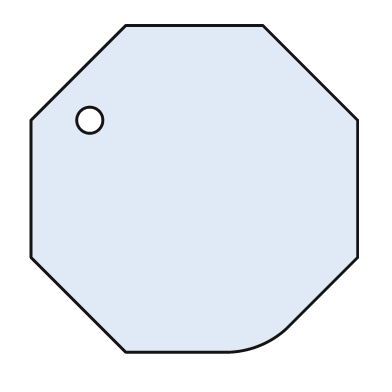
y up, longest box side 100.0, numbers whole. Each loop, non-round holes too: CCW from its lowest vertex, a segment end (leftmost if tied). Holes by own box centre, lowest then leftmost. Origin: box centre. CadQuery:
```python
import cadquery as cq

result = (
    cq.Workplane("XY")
    .moveTo(-21.0, -50.0)
    .lineTo(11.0, -50.0)
    .threePointArc((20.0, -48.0), (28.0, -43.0))
    .lineTo(50.0, -21.0)
    .lineTo(50.0, 21.0)
    .lineTo(21.0, 50.0)
    .lineTo(-21.0, 50.0)
    .lineTo(-50.0, 21.0)
    .lineTo(-50.0, -21.0)
    .close()
    .moveTo(-32.0, 21.0)
    .circle(4.0)
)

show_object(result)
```